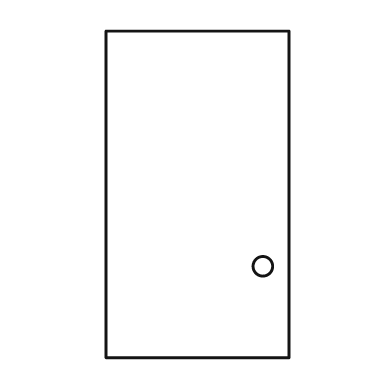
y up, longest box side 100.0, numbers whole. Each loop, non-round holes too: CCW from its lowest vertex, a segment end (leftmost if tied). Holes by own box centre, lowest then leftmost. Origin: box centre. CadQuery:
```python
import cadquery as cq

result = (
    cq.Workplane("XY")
    .moveTo(-28.0, -50.0)
    .lineTo(28.0, -50.0)
    .lineTo(28.0, 50.0)
    .lineTo(-28.0, 50.0)
    .close()
    .moveTo(20.0, -22.0)
    .circle(3.0)
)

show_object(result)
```